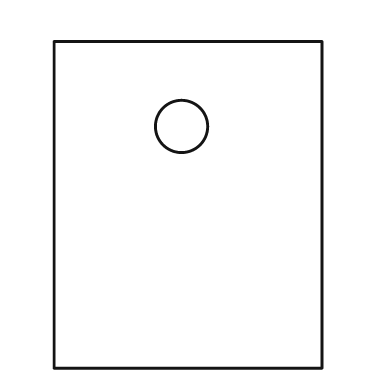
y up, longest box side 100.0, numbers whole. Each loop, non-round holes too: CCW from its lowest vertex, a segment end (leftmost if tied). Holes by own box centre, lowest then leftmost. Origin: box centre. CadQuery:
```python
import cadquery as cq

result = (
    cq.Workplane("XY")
    .moveTo(-41.0, -50.0)
    .lineTo(41.0, -50.0)
    .lineTo(41.0, 50.0)
    .lineTo(-41.0, 50.0)
    .close()
    .moveTo(-2.0, 24.0)
    .circle(8.0)
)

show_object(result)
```